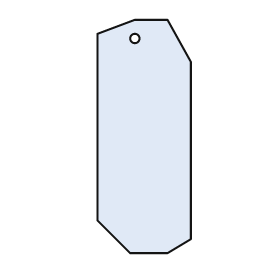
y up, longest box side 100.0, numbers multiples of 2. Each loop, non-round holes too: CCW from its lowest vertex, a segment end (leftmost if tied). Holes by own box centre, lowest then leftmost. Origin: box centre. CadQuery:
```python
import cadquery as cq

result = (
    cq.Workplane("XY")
    .moveTo(-6.0, -50.0)
    .lineTo(10.0, -50.0)
    .lineTo(20.0, -44.0)
    .lineTo(20.0, 32.0)
    .lineTo(10.0, 50.0)
    .lineTo(-4.0, 50.0)
    .lineTo(-20.0, 44.0)
    .lineTo(-20.0, -36.0)
    .close()
    .moveTo(-4.0, 42.0)
    .circle(2.0)
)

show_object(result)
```